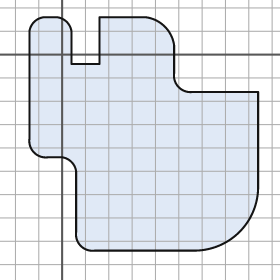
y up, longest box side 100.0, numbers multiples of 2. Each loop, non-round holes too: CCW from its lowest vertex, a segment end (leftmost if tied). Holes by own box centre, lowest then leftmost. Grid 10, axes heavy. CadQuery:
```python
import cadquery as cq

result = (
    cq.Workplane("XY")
    .moveTo(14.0, -84.0)
    .lineTo(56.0, -84.0)
    .threePointArc((76.0, -76.0), (84.0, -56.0))
    .lineTo(84.0, -16.0)
    .lineTo(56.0, -16.0)
    .threePointArc((50.0, -14.0), (48.0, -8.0))
    .lineTo(48.0, 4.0)
    .threePointArc((44.0, 12.0), (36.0, 16.0))
    .lineTo(16.0, 16.0)
    .lineTo(16.0, -4.0)
    .lineTo(4.0, -4.0)
    .lineTo(4.0, 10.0)
    .threePointArc((2.0, 14.0), (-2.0, 16.0))
    .lineTo(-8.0, 16.0)
    .threePointArc((-12.0, 14.0), (-14.0, 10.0))
    .lineTo(-14.0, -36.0)
    .threePointArc((-12.0, -42.0), (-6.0, -44.0))
    .lineTo(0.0, -44.0)
    .threePointArc((4.0, -46.0), (6.0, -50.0))
    .lineTo(6.0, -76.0)
    .threePointArc((8.0, -82.0), (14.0, -84.0))
    .close()
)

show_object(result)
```